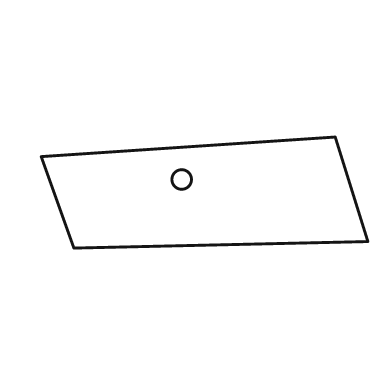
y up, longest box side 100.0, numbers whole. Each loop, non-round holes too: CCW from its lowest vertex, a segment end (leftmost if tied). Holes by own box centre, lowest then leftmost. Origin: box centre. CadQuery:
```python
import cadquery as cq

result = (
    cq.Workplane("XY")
    .moveTo(-40.0, -17.0)
    .lineTo(50.0, -15.0)
    .lineTo(40.0, 17.0)
    .lineTo(-50.0, 11.0)
    .close()
    .moveTo(-7.0, 4.0)
    .circle(3.0)
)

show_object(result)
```